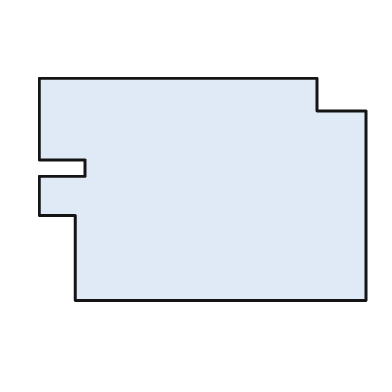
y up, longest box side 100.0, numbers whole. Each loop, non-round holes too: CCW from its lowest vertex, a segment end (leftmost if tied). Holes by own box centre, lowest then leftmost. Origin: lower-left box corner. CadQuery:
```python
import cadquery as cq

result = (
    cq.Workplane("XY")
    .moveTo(11.0, 0.0)
    .lineTo(100.0, 0.0)
    .lineTo(100.0, 58.0)
    .lineTo(85.0, 58.0)
    .lineTo(85.0, 68.0)
    .lineTo(0.0, 68.0)
    .lineTo(0.0, 43.0)
    .lineTo(14.0, 43.0)
    .lineTo(14.0, 38.0)
    .lineTo(0.0, 38.0)
    .lineTo(0.0, 26.0)
    .lineTo(11.0, 26.0)
    .close()
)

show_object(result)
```